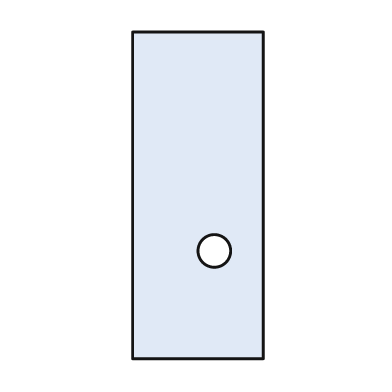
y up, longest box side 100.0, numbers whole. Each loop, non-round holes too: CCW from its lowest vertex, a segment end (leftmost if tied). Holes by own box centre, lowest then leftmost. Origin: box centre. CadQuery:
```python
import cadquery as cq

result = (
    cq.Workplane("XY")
    .moveTo(-20.0, -50.0)
    .lineTo(20.0, -50.0)
    .lineTo(20.0, 50.0)
    .lineTo(-20.0, 50.0)
    .close()
    .moveTo(5.0, -17.0)
    .circle(5.0)
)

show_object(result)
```